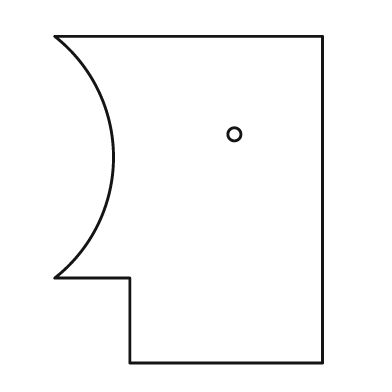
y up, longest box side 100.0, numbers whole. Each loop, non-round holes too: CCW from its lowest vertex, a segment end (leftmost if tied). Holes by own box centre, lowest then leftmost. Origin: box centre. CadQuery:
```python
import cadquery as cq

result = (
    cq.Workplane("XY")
    .moveTo(-18.0, -50.0)
    .lineTo(41.0, -50.0)
    .lineTo(41.0, 50.0)
    .lineTo(-41.0, 50.0)
    .threePointArc((-23.0, 13.0), (-41.0, -24.0))
    .lineTo(-18.0, -24.0)
    .close()
    .moveTo(14.0, 20.0)
    .circle(2.0)
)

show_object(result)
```